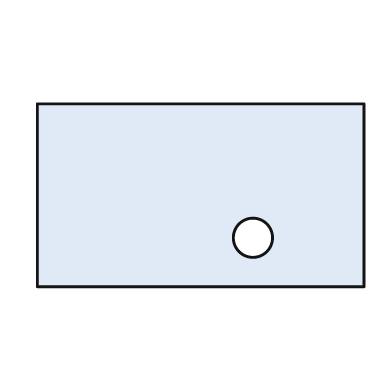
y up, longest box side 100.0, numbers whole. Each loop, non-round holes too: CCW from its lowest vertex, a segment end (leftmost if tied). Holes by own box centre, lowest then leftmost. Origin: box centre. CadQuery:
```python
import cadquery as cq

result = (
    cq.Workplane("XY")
    .moveTo(-50.0, -28.0)
    .lineTo(50.0, -28.0)
    .lineTo(50.0, 28.0)
    .lineTo(-50.0, 28.0)
    .close()
    .moveTo(16.0, -13.0)
    .circle(6.0)
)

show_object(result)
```